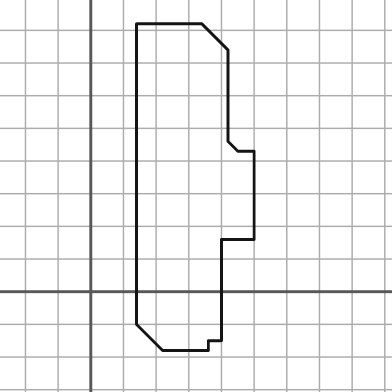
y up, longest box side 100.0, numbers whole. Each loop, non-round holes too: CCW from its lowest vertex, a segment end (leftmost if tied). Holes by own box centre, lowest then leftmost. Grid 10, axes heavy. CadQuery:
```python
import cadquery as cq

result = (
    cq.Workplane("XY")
    .moveTo(22.0, -18.0)
    .lineTo(36.0, -18.0)
    .lineTo(36.0, -15.0)
    .lineTo(40.0, -15.0)
    .lineTo(40.0, 16.0)
    .lineTo(50.0, 16.0)
    .lineTo(50.0, 43.0)
    .lineTo(45.0, 43.0)
    .lineTo(42.0, 46.0)
    .lineTo(42.0, 74.0)
    .lineTo(34.0, 82.0)
    .lineTo(14.0, 82.0)
    .lineTo(14.0, -10.0)
    .close()
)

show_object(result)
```